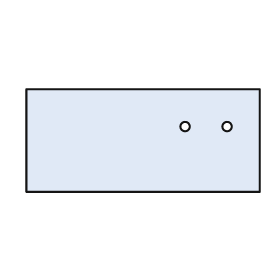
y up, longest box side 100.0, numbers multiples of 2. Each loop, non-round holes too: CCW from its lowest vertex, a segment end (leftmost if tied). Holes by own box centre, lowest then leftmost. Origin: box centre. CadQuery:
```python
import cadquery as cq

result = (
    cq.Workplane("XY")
    .moveTo(-50.0, -22.0)
    .lineTo(50.0, -22.0)
    .lineTo(50.0, 22.0)
    .lineTo(-50.0, 22.0)
    .close()
    .moveTo(18.0, 6.0)
    .circle(2.0)
    .moveTo(36.0, 6.0)
    .circle(2.0)
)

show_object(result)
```